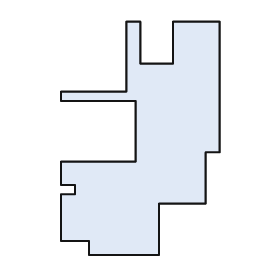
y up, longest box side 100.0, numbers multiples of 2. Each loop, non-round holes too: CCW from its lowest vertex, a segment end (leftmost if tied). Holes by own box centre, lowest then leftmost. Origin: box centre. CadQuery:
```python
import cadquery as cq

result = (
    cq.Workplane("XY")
    .moveTo(-22.0, -50.0)
    .lineTo(8.0, -50.0)
    .lineTo(8.0, -28.0)
    .lineTo(28.0, -28.0)
    .lineTo(28.0, -6.0)
    .lineTo(34.0, -6.0)
    .lineTo(34.0, 50.0)
    .lineTo(14.0, 50.0)
    .lineTo(14.0, 32.0)
    .lineTo(0.0, 32.0)
    .lineTo(0.0, 50.0)
    .lineTo(-6.0, 50.0)
    .lineTo(-6.0, 20.0)
    .lineTo(-34.0, 20.0)
    .lineTo(-34.0, 16.0)
    .lineTo(-2.0, 16.0)
    .lineTo(-2.0, -10.0)
    .lineTo(-34.0, -10.0)
    .lineTo(-34.0, -20.0)
    .lineTo(-28.0, -20.0)
    .lineTo(-28.0, -24.0)
    .lineTo(-34.0, -24.0)
    .lineTo(-34.0, -44.0)
    .lineTo(-22.0, -44.0)
    .close()
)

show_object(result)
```